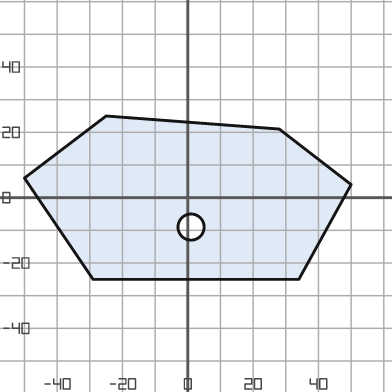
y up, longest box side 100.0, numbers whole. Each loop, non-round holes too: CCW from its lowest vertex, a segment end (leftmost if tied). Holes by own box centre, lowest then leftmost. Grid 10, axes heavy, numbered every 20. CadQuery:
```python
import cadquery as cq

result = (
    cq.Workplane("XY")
    .moveTo(-29.0, -25.0)
    .lineTo(34.0, -25.0)
    .lineTo(50.0, 4.0)
    .lineTo(28.0, 21.0)
    .lineTo(-25.0, 25.0)
    .lineTo(-50.0, 6.0)
    .close()
    .moveTo(1.0, -9.0)
    .circle(4.0)
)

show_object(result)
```